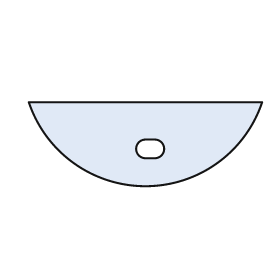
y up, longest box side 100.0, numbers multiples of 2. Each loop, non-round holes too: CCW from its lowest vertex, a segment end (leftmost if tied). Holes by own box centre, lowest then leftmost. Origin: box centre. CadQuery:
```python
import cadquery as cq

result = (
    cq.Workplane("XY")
    .moveTo(-50.0, 18.0)
    .threePointArc((0.0, -18.0), (50.0, 18.0))
    .close()
    .moveTo(0.0, -6.0)
    .lineTo(4.0, -6.0)
    .threePointArc((8.0, -2.0), (4.0, 2.0))
    .lineTo(0.0, 2.0)
    .threePointArc((-4.0, -2.0), (0.0, -6.0))
    .close()
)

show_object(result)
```